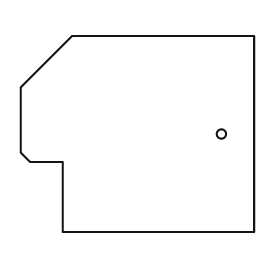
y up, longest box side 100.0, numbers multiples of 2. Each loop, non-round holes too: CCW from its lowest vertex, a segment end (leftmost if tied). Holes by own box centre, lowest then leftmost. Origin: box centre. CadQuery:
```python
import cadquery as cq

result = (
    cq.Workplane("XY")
    .moveTo(-32.0, -42.0)
    .lineTo(50.0, -42.0)
    .lineTo(50.0, 42.0)
    .lineTo(-28.0, 42.0)
    .lineTo(-50.0, 20.0)
    .lineTo(-50.0, -8.0)
    .lineTo(-46.0, -12.0)
    .lineTo(-32.0, -12.0)
    .close()
    .moveTo(36.0, 0.0)
    .circle(2.0)
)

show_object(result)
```